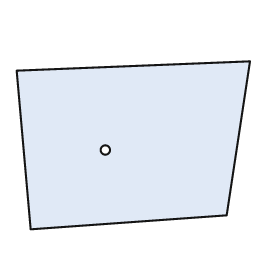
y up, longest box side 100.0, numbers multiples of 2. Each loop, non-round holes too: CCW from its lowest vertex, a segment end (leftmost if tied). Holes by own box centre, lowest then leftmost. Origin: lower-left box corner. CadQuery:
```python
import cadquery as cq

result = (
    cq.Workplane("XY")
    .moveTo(6.0, 0.0)
    .lineTo(90.0, 6.0)
    .lineTo(100.0, 72.0)
    .lineTo(0.0, 68.0)
    .close()
    .moveTo(38.0, 34.0)
    .circle(2.0)
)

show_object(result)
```